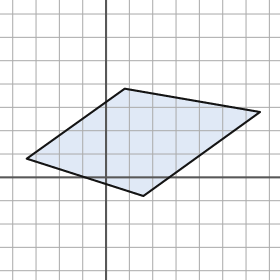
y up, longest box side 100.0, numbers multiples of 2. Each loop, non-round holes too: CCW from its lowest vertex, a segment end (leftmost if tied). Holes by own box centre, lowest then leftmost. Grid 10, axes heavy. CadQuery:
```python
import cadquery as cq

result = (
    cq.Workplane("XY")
    .moveTo(16.0, -8.0)
    .lineTo(66.0, 28.0)
    .lineTo(8.0, 38.0)
    .lineTo(-34.0, 8.0)
    .close()
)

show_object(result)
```